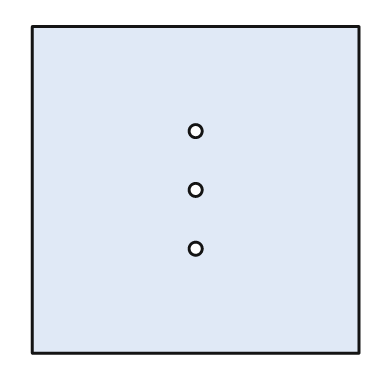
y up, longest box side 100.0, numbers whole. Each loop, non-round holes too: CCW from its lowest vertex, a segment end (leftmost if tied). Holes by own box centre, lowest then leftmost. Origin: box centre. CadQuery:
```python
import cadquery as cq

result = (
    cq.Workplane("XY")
    .moveTo(-50.0, -50.0)
    .lineTo(50.0, -50.0)
    .lineTo(50.0, 50.0)
    .lineTo(-50.0, 50.0)
    .close()
    .moveTo(0.0, -18.0)
    .circle(2.0)
    .moveTo(0.0, 0.0)
    .circle(2.0)
    .moveTo(0.0, 18.0)
    .circle(2.0)
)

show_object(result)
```